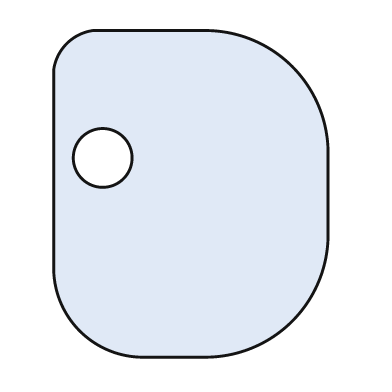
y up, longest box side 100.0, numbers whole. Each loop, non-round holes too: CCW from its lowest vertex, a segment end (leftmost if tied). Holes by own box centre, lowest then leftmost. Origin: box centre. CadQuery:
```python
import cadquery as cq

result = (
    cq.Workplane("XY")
    .moveTo(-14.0, -50.0)
    .lineTo(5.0, -50.0)
    .threePointArc((31.0, -39.0), (42.0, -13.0))
    .lineTo(42.0, 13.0)
    .threePointArc((31.0, 39.0), (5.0, 50.0))
    .lineTo(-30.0, 50.0)
    .threePointArc((-38.0, 46.0), (-42.0, 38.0))
    .lineTo(-42.0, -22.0)
    .threePointArc((-34.0, -42.0), (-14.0, -50.0))
    .close()
    .moveTo(-27.0, 11.0)
    .circle(9.0)
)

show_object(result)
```